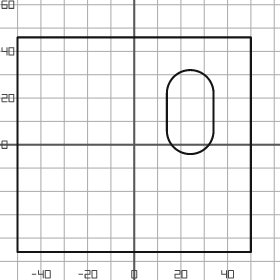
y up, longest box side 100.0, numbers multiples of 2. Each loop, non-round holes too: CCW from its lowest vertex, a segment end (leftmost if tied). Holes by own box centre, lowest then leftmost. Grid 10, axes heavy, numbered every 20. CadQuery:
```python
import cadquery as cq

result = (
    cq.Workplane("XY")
    .moveTo(-50.0, -46.0)
    .lineTo(50.0, -46.0)
    .lineTo(50.0, 46.0)
    .lineTo(-50.0, 46.0)
    .close()
    .moveTo(14.0, 6.0)
    .threePointArc((24.0, -4.0), (34.0, 6.0))
    .lineTo(34.0, 22.0)
    .threePointArc((24.0, 32.0), (14.0, 22.0))
    .close()
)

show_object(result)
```